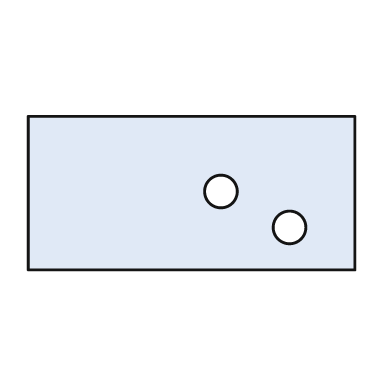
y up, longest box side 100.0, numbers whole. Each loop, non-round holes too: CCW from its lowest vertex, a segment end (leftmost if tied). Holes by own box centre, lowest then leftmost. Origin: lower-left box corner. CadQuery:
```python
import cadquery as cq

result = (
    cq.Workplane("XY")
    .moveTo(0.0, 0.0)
    .lineTo(100.0, 0.0)
    .lineTo(100.0, 47.0)
    .lineTo(0.0, 47.0)
    .close()
    .moveTo(80.0, 13.0)
    .circle(5.0)
    .moveTo(59.0, 24.0)
    .circle(5.0)
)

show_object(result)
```